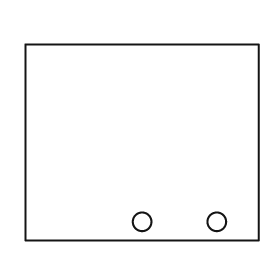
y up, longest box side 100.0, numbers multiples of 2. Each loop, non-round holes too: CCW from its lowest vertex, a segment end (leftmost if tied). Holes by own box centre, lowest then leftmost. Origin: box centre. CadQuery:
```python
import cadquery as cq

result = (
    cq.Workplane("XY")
    .moveTo(-50.0, -42.0)
    .lineTo(50.0, -42.0)
    .lineTo(50.0, 42.0)
    .lineTo(-50.0, 42.0)
    .close()
    .moveTo(0.0, -34.0)
    .circle(4.0)
    .moveTo(32.0, -34.0)
    .circle(4.0)
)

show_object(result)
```